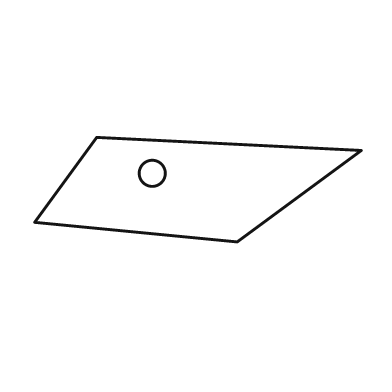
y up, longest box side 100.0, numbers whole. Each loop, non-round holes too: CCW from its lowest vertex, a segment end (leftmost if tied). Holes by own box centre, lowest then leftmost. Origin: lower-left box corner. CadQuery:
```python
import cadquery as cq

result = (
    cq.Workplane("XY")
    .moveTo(62.0, 0.0)
    .lineTo(100.0, 28.0)
    .lineTo(19.0, 32.0)
    .lineTo(0.0, 6.0)
    .close()
    .moveTo(36.0, 21.0)
    .circle(4.0)
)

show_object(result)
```